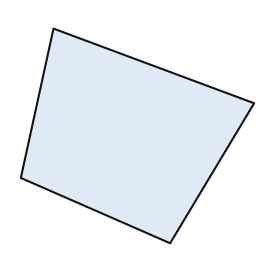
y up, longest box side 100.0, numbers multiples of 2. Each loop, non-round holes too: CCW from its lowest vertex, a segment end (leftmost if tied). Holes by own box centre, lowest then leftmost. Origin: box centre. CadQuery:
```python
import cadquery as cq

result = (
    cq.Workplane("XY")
    .moveTo(14.0, -46.0)
    .lineTo(50.0, 14.0)
    .lineTo(-36.0, 46.0)
    .lineTo(-50.0, -18.0)
    .close()
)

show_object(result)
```